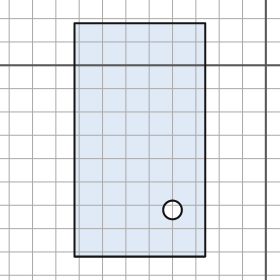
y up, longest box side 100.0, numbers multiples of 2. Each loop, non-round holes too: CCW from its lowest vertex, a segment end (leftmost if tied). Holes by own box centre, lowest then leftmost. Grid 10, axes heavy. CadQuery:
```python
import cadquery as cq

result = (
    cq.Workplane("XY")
    .moveTo(-82.0, -82.0)
    .lineTo(-26.0, -82.0)
    .lineTo(-26.0, 18.0)
    .lineTo(-82.0, 18.0)
    .close()
    .moveTo(-40.0, -62.0)
    .circle(4.0)
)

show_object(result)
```